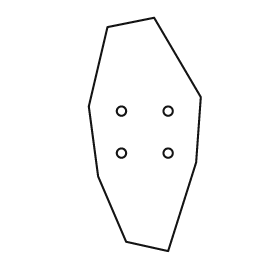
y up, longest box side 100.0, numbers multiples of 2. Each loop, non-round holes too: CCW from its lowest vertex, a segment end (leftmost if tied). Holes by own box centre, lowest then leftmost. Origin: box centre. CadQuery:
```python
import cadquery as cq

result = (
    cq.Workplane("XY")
    .moveTo(10.0, -50.0)
    .lineTo(22.0, -12.0)
    .lineTo(24.0, 16.0)
    .lineTo(4.0, 50.0)
    .lineTo(-16.0, 46.0)
    .lineTo(-24.0, 12.0)
    .lineTo(-20.0, -18.0)
    .lineTo(-8.0, -46.0)
    .close()
    .moveTo(-10.0, -8.0)
    .circle(2.0)
    .moveTo(10.0, -8.0)
    .circle(2.0)
    .moveTo(-10.0, 10.0)
    .circle(2.0)
    .moveTo(10.0, 10.0)
    .circle(2.0)
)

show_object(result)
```